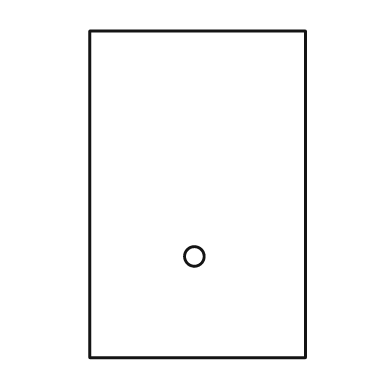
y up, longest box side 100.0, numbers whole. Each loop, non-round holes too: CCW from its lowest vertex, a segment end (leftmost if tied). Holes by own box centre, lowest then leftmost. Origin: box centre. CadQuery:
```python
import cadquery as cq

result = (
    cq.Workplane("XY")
    .moveTo(-33.0, -50.0)
    .lineTo(33.0, -50.0)
    .lineTo(33.0, 50.0)
    .lineTo(-33.0, 50.0)
    .close()
    .moveTo(-1.0, -19.0)
    .circle(3.0)
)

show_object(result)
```